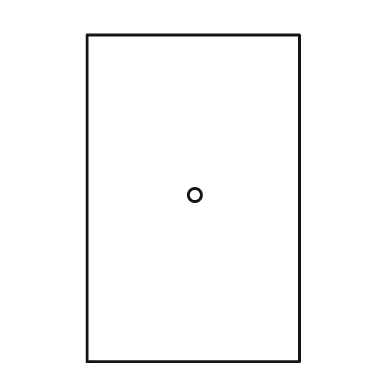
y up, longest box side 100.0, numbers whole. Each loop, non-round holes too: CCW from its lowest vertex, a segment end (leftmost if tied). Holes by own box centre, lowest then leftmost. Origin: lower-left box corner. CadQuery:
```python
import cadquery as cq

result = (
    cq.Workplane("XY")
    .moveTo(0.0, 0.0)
    .lineTo(65.0, 0.0)
    .lineTo(65.0, 100.0)
    .lineTo(0.0, 100.0)
    .close()
    .moveTo(33.0, 51.0)
    .circle(2.0)
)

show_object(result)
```